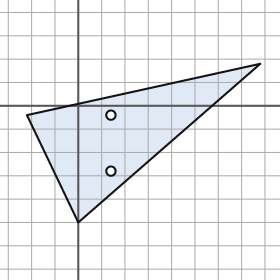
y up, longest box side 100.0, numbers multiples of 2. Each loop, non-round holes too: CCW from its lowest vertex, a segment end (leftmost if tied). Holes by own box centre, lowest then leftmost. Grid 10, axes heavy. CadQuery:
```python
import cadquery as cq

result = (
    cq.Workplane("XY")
    .moveTo(0.0, -50.0)
    .lineTo(78.0, 18.0)
    .lineTo(-22.0, -4.0)
    .close()
    .moveTo(14.0, -28.0)
    .circle(2.0)
    .moveTo(14.0, -4.0)
    .circle(2.0)
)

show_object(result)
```